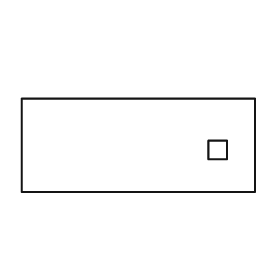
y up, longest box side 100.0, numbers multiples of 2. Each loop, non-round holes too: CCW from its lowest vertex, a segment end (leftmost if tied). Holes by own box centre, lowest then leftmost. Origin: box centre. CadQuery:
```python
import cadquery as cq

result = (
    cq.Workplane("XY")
    .moveTo(-50.0, -20.0)
    .lineTo(50.0, -20.0)
    .lineTo(50.0, 20.0)
    .lineTo(-50.0, 20.0)
    .close()
    .moveTo(30.0, -6.0)
    .lineTo(38.0, -6.0)
    .lineTo(38.0, 2.0)
    .lineTo(30.0, 2.0)
    .close()
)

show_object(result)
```